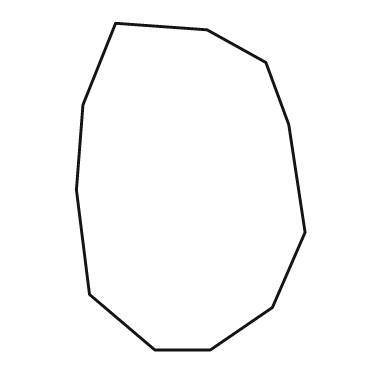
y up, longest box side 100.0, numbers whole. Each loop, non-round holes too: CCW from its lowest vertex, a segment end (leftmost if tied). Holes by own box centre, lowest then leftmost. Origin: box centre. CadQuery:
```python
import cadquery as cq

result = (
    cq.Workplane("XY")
    .moveTo(-11.0, -50.0)
    .lineTo(6.0, -50.0)
    .lineTo(25.0, -37.0)
    .lineTo(35.0, -14.0)
    .lineTo(30.0, 19.0)
    .lineTo(23.0, 38.0)
    .lineTo(5.0, 48.0)
    .lineTo(-23.0, 50.0)
    .lineTo(-33.0, 25.0)
    .lineTo(-35.0, -1.0)
    .lineTo(-31.0, -33.0)
    .close()
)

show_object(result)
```